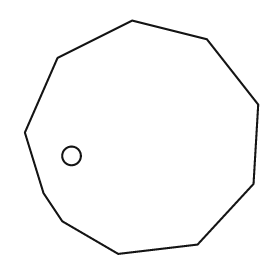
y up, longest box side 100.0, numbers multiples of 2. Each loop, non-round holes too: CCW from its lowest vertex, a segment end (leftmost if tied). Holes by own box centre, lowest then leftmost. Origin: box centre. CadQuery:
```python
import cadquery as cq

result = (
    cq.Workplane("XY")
    .moveTo(-10.0, -50.0)
    .lineTo(24.0, -46.0)
    .lineTo(48.0, -20.0)
    .lineTo(50.0, 14.0)
    .lineTo(28.0, 42.0)
    .lineTo(-4.0, 50.0)
    .lineTo(-36.0, 34.0)
    .lineTo(-50.0, 2.0)
    .lineTo(-42.0, -24.0)
    .lineTo(-34.0, -36.0)
    .close()
    .moveTo(-30.0, -8.0)
    .circle(4.0)
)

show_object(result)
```